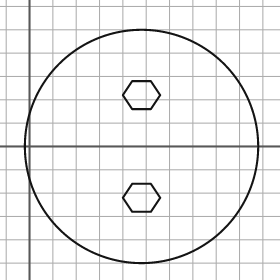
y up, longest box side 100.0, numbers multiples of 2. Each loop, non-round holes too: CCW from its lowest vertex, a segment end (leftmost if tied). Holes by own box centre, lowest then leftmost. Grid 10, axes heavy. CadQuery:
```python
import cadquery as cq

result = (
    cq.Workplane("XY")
    .moveTo(48.0, 0.0)
    .circle(50.0)
    .moveTo(44.0, -28.0)
    .lineTo(52.0, -28.0)
    .lineTo(56.0, -22.0)
    .lineTo(52.0, -16.0)
    .lineTo(44.0, -16.0)
    .lineTo(40.0, -22.0)
    .close()
    .moveTo(44.0, 16.0)
    .lineTo(52.0, 16.0)
    .lineTo(56.0, 22.0)
    .lineTo(52.0, 28.0)
    .lineTo(44.0, 28.0)
    .lineTo(40.0, 22.0)
    .close()
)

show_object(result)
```